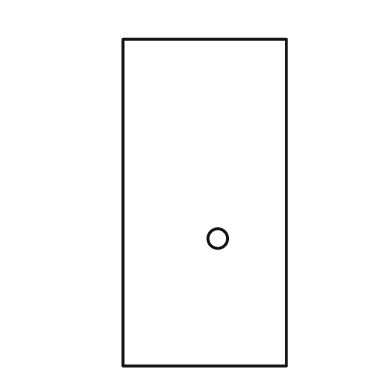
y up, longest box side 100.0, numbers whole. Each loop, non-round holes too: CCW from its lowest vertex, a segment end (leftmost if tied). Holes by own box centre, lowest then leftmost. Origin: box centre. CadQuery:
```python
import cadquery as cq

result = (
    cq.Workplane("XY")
    .moveTo(-25.0, -50.0)
    .lineTo(25.0, -50.0)
    .lineTo(25.0, 50.0)
    .lineTo(-25.0, 50.0)
    .close()
    .moveTo(4.0, -11.0)
    .circle(3.0)
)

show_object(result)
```